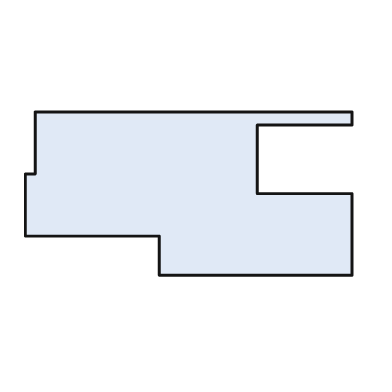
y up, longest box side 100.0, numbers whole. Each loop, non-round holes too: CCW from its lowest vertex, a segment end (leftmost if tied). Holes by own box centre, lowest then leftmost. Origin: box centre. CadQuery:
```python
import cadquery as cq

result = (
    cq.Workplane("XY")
    .moveTo(-9.0, -25.0)
    .lineTo(50.0, -25.0)
    .lineTo(50.0, 0.0)
    .lineTo(21.0, 0.0)
    .lineTo(21.0, 21.0)
    .lineTo(50.0, 21.0)
    .lineTo(50.0, 25.0)
    .lineTo(-47.0, 25.0)
    .lineTo(-47.0, 6.0)
    .lineTo(-50.0, 6.0)
    .lineTo(-50.0, -13.0)
    .lineTo(-9.0, -13.0)
    .close()
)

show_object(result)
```